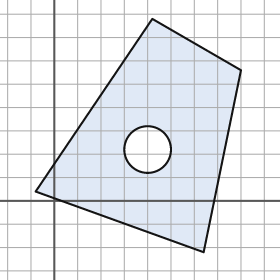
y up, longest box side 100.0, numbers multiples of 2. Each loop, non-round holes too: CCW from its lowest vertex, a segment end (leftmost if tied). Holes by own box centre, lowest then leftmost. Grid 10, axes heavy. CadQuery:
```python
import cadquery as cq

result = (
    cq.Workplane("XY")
    .moveTo(64.0, -22.0)
    .lineTo(80.0, 56.0)
    .lineTo(42.0, 78.0)
    .lineTo(-8.0, 4.0)
    .close()
    .moveTo(40.0, 22.0)
    .circle(10.0)
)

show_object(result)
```